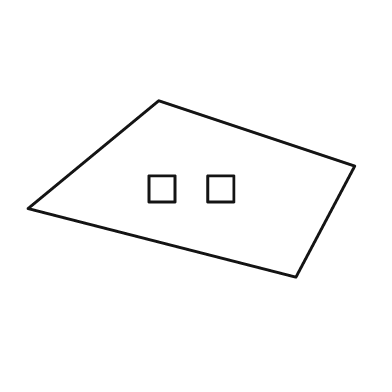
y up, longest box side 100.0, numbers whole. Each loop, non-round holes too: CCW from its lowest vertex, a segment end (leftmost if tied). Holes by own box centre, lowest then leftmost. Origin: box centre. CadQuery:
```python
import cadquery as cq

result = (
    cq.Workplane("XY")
    .moveTo(32.0, -27.0)
    .lineTo(50.0, 7.0)
    .lineTo(-10.0, 27.0)
    .lineTo(-50.0, -6.0)
    .close()
    .moveTo(-13.0, -4.0)
    .lineTo(-5.0, -4.0)
    .lineTo(-5.0, 4.0)
    .lineTo(-13.0, 4.0)
    .close()
    .moveTo(5.0, -4.0)
    .lineTo(13.0, -4.0)
    .lineTo(13.0, 4.0)
    .lineTo(5.0, 4.0)
    .close()
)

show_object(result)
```